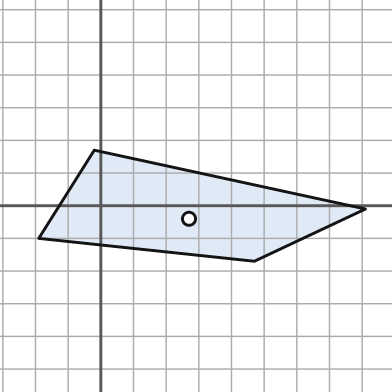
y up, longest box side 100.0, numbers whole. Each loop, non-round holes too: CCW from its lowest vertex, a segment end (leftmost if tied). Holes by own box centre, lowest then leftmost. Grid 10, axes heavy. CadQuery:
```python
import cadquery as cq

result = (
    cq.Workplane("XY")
    .moveTo(47.0, -17.0)
    .lineTo(81.0, -1.0)
    .lineTo(-2.0, 17.0)
    .lineTo(-19.0, -10.0)
    .close()
    .moveTo(27.0, -4.0)
    .circle(2.0)
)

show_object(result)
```